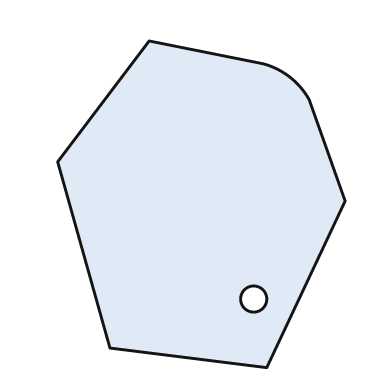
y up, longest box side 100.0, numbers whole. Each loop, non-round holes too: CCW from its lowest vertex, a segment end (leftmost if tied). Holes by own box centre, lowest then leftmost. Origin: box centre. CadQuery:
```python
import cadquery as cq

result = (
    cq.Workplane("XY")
    .moveTo(20.0, -50.0)
    .lineTo(44.0, 1.0)
    .lineTo(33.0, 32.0)
    .threePointArc((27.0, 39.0), (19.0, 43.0))
    .lineTo(-16.0, 50.0)
    .lineTo(-44.0, 13.0)
    .lineTo(-28.0, -44.0)
    .close()
    .moveTo(16.0, -29.0)
    .circle(4.0)
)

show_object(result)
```